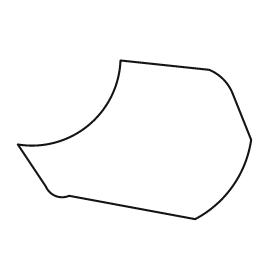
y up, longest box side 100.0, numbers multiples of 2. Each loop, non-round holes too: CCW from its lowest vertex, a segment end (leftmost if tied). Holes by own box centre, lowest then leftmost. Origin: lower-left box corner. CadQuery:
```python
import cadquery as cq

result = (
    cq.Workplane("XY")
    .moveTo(76.0, 0.0)
    .threePointArc((92.0, 14.0), (100.0, 34.0))
    .lineTo(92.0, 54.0)
    .threePointArc((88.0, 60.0), (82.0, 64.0))
    .lineTo(44.0, 68.0)
    .threePointArc((30.0, 40.0), (0.0, 32.0))
    .lineTo(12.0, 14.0)
    .threePointArc((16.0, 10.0), (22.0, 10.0))
    .close()
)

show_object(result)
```